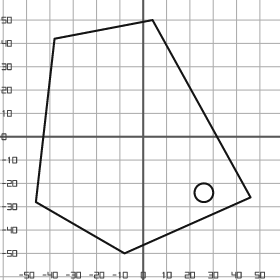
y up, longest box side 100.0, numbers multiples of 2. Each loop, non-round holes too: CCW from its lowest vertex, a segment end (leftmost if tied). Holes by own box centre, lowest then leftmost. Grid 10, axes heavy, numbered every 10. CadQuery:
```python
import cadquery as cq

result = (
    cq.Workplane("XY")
    .moveTo(-8.0, -50.0)
    .lineTo(46.0, -26.0)
    .lineTo(4.0, 50.0)
    .lineTo(-38.0, 42.0)
    .lineTo(-46.0, -28.0)
    .close()
    .moveTo(26.0, -24.0)
    .circle(4.0)
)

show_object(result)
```